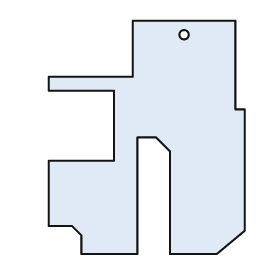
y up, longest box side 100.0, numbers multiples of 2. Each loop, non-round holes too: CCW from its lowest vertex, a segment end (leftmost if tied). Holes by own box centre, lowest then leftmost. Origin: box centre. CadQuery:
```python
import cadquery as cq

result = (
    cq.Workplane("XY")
    .moveTo(-28.0, -50.0)
    .lineTo(-4.0, -50.0)
    .lineTo(-4.0, 0.0)
    .lineTo(4.0, 0.0)
    .lineTo(10.0, -6.0)
    .lineTo(10.0, -50.0)
    .lineTo(30.0, -50.0)
    .lineTo(42.0, -40.0)
    .lineTo(42.0, 12.0)
    .lineTo(38.0, 12.0)
    .lineTo(38.0, 50.0)
    .lineTo(-6.0, 50.0)
    .lineTo(-6.0, 26.0)
    .lineTo(-42.0, 26.0)
    .lineTo(-42.0, 20.0)
    .lineTo(-14.0, 20.0)
    .lineTo(-14.0, -10.0)
    .lineTo(-42.0, -10.0)
    .lineTo(-42.0, -38.0)
    .lineTo(-32.0, -38.0)
    .lineTo(-28.0, -42.0)
    .close()
    .moveTo(16.0, 44.0)
    .circle(2.0)
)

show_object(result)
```